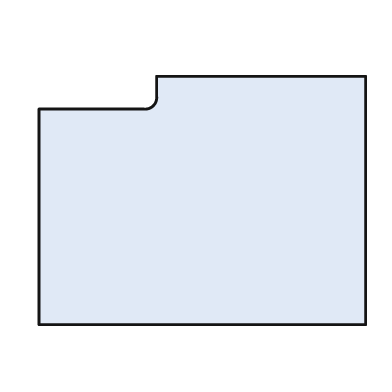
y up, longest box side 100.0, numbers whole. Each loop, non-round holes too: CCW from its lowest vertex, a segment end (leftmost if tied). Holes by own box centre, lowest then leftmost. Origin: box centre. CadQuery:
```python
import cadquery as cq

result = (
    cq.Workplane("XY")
    .moveTo(-50.0, -38.0)
    .lineTo(50.0, -38.0)
    .lineTo(50.0, 38.0)
    .lineTo(-14.0, 38.0)
    .lineTo(-14.0, 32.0)
    .threePointArc((-15.0, 29.0), (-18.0, 28.0))
    .lineTo(-50.0, 28.0)
    .close()
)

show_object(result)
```